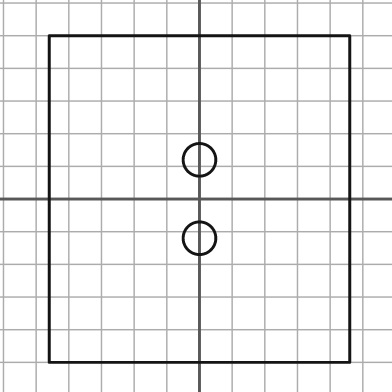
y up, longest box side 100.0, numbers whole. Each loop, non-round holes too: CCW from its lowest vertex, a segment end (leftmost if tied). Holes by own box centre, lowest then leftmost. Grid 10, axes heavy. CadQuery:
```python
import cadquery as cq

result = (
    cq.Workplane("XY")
    .moveTo(-46.0, -50.0)
    .lineTo(46.0, -50.0)
    .lineTo(46.0, 50.0)
    .lineTo(-46.0, 50.0)
    .close()
    .moveTo(0.0, -12.0)
    .circle(5.0)
    .moveTo(0.0, 12.0)
    .circle(5.0)
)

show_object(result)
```